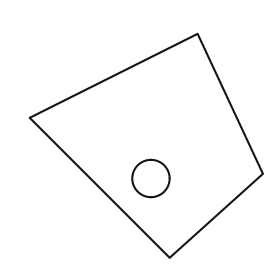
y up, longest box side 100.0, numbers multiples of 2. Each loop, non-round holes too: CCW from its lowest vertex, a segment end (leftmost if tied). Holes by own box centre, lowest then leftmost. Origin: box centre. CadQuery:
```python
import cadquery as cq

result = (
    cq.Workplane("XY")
    .moveTo(10.0, -48.0)
    .lineTo(50.0, -12.0)
    .lineTo(22.0, 48.0)
    .lineTo(-50.0, 12.0)
    .close()
    .moveTo(2.0, -14.0)
    .circle(8.0)
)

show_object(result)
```